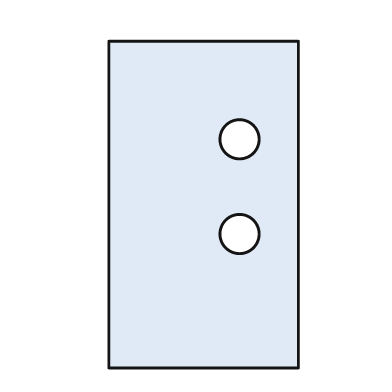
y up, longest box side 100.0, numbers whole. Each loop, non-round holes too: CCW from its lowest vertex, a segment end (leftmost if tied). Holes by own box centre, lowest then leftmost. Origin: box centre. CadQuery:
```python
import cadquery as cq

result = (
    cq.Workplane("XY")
    .moveTo(-29.0, -50.0)
    .lineTo(29.0, -50.0)
    .lineTo(29.0, 50.0)
    .lineTo(-29.0, 50.0)
    .close()
    .moveTo(11.0, -9.0)
    .circle(6.0)
    .moveTo(11.0, 20.0)
    .circle(6.0)
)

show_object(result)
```